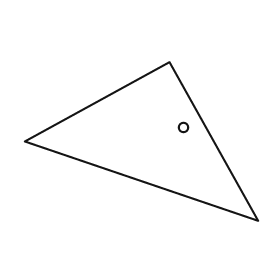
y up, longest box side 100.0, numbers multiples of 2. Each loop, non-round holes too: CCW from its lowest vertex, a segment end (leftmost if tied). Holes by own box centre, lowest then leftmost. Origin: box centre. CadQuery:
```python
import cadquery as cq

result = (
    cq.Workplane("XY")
    .moveTo(50.0, -34.0)
    .lineTo(12.0, 34.0)
    .lineTo(-50.0, 0.0)
    .close()
    .moveTo(18.0, 6.0)
    .circle(2.0)
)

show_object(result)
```